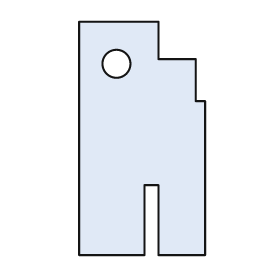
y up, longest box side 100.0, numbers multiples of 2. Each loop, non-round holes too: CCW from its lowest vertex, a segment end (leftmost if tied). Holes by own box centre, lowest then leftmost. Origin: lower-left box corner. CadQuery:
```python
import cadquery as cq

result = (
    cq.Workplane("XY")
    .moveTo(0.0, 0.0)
    .lineTo(28.0, 0.0)
    .lineTo(28.0, 30.0)
    .lineTo(34.0, 30.0)
    .lineTo(34.0, 0.0)
    .lineTo(54.0, 0.0)
    .lineTo(54.0, 66.0)
    .lineTo(50.0, 66.0)
    .lineTo(50.0, 84.0)
    .lineTo(34.0, 84.0)
    .lineTo(34.0, 100.0)
    .lineTo(0.0, 100.0)
    .close()
    .moveTo(16.0, 82.0)
    .circle(6.0)
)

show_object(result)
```